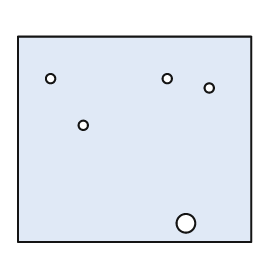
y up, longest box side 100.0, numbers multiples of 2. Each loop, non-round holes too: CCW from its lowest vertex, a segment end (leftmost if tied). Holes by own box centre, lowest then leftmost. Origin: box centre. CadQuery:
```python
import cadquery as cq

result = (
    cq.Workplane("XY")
    .moveTo(-50.0, -44.0)
    .lineTo(50.0, -44.0)
    .lineTo(50.0, 44.0)
    .lineTo(-50.0, 44.0)
    .close()
    .moveTo(22.0, -36.0)
    .circle(4.0)
    .moveTo(-22.0, 6.0)
    .circle(2.0)
    .moveTo(32.0, 22.0)
    .circle(2.0)
    .moveTo(-36.0, 26.0)
    .circle(2.0)
    .moveTo(14.0, 26.0)
    .circle(2.0)
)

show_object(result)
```